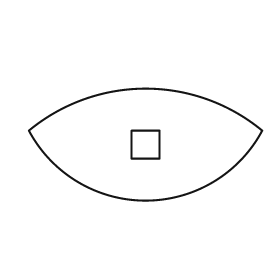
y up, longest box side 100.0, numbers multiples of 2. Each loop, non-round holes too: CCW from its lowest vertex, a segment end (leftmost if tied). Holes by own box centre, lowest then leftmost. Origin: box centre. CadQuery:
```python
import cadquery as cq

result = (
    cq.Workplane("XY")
    .moveTo(-50.0, 6.0)
    .threePointArc((0.0, -24.0), (50.0, 6.0))
    .threePointArc((0.0, 24.0), (-50.0, 6.0))
    .close()
    .moveTo(-6.0, -6.0)
    .lineTo(6.0, -6.0)
    .lineTo(6.0, 6.0)
    .lineTo(-6.0, 6.0)
    .close()
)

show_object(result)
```